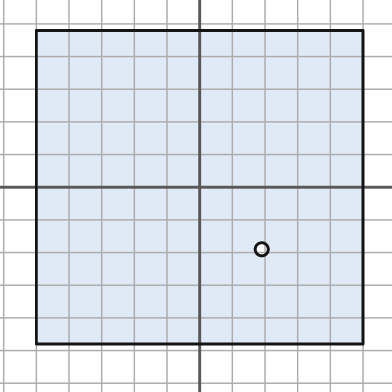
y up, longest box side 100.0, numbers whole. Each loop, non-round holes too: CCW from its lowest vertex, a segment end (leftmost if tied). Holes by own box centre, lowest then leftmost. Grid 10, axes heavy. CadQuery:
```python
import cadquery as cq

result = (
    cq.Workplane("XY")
    .moveTo(-50.0, -48.0)
    .lineTo(50.0, -48.0)
    .lineTo(50.0, 48.0)
    .lineTo(-50.0, 48.0)
    .close()
    .moveTo(19.0, -19.0)
    .circle(2.0)
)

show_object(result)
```